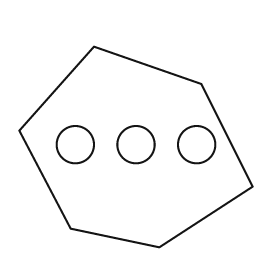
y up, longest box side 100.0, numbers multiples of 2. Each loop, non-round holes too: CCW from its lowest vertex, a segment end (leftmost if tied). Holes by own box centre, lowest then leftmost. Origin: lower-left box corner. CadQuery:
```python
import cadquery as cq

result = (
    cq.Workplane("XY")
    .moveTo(60.0, 0.0)
    .lineTo(100.0, 26.0)
    .lineTo(78.0, 70.0)
    .lineTo(32.0, 86.0)
    .lineTo(0.0, 50.0)
    .lineTo(22.0, 8.0)
    .close()
    .moveTo(24.0, 44.0)
    .circle(8.0)
    .moveTo(50.0, 44.0)
    .circle(8.0)
    .moveTo(76.0, 44.0)
    .circle(8.0)
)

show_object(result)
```